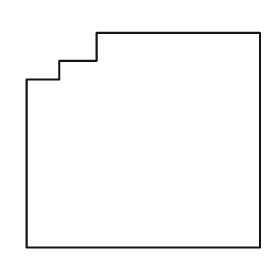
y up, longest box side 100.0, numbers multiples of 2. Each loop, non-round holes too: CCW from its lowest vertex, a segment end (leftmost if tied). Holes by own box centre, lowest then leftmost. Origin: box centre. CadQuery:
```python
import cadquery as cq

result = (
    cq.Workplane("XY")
    .moveTo(-50.0, -46.0)
    .lineTo(50.0, -46.0)
    .lineTo(50.0, 46.0)
    .lineTo(-20.0, 46.0)
    .lineTo(-20.0, 34.0)
    .lineTo(-36.0, 34.0)
    .lineTo(-36.0, 26.0)
    .lineTo(-50.0, 26.0)
    .close()
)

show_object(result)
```